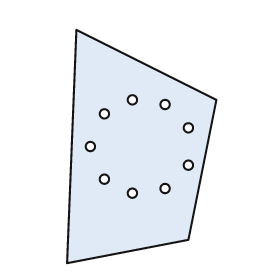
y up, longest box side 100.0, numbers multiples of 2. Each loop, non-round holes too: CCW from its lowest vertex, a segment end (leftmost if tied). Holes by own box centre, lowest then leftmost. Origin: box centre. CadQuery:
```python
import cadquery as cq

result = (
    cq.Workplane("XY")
    .moveTo(-32.0, -50.0)
    .lineTo(20.0, -40.0)
    .lineTo(32.0, 20.0)
    .lineTo(-28.0, 50.0)
    .close()
    .moveTo(-4.0, -20.0)
    .circle(2.0)
    .moveTo(10.0, -18.0)
    .circle(2.0)
    .moveTo(-16.0, -14.0)
    .circle(2.0)
    .moveTo(20.0, -8.0)
    .circle(2.0)
    .moveTo(-22.0, 0.0)
    .circle(2.0)
    .moveTo(20.0, 8.0)
    .circle(2.0)
    .moveTo(-16.0, 14.0)
    .circle(2.0)
    .moveTo(10.0, 18.0)
    .circle(2.0)
    .moveTo(-4.0, 20.0)
    .circle(2.0)
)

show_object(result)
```